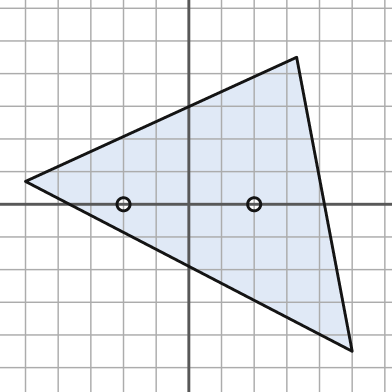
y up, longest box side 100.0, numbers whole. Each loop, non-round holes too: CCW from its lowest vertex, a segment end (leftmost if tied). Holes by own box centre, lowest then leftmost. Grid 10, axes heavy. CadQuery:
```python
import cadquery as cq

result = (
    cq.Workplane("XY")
    .moveTo(50.0, -45.0)
    .lineTo(33.0, 45.0)
    .lineTo(-50.0, 7.0)
    .close()
    .moveTo(-20.0, 0.0)
    .circle(2.0)
    .moveTo(20.0, 0.0)
    .circle(2.0)
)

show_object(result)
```